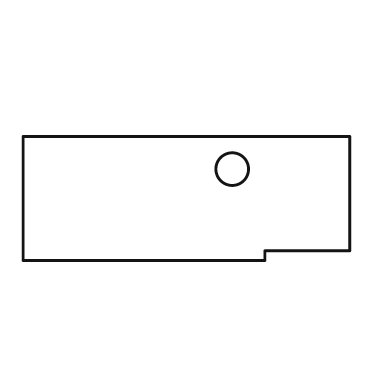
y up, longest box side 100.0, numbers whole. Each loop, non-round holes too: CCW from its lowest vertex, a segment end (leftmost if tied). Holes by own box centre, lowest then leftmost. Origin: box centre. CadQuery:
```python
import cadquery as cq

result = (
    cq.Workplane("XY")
    .moveTo(-50.0, -19.0)
    .lineTo(24.0, -19.0)
    .lineTo(24.0, -16.0)
    .lineTo(50.0, -16.0)
    .lineTo(50.0, 19.0)
    .lineTo(-50.0, 19.0)
    .close()
    .moveTo(14.0, 9.0)
    .circle(5.0)
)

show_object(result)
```